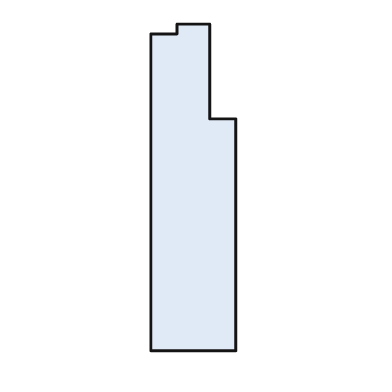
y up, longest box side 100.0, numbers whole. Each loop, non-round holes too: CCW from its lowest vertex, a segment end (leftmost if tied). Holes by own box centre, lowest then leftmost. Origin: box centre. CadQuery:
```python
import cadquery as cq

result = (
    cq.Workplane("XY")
    .moveTo(-13.0, -50.0)
    .lineTo(13.0, -50.0)
    .lineTo(13.0, 21.0)
    .lineTo(5.0, 21.0)
    .lineTo(5.0, 50.0)
    .lineTo(-5.0, 50.0)
    .lineTo(-5.0, 47.0)
    .lineTo(-13.0, 47.0)
    .close()
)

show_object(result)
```